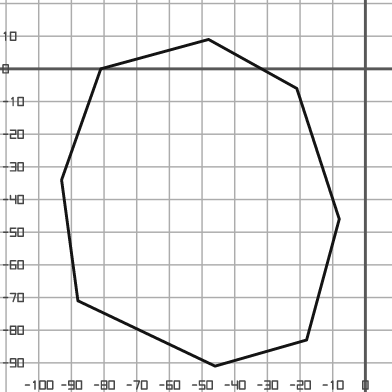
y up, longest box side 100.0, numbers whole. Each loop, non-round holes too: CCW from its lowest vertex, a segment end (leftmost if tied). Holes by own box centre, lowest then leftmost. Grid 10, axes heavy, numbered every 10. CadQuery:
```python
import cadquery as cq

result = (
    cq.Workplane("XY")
    .moveTo(-46.0, -91.0)
    .lineTo(-18.0, -83.0)
    .lineTo(-8.0, -46.0)
    .lineTo(-21.0, -6.0)
    .lineTo(-48.0, 9.0)
    .lineTo(-81.0, 0.0)
    .lineTo(-93.0, -34.0)
    .lineTo(-88.0, -71.0)
    .close()
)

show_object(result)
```